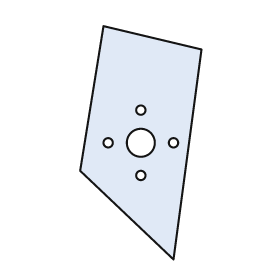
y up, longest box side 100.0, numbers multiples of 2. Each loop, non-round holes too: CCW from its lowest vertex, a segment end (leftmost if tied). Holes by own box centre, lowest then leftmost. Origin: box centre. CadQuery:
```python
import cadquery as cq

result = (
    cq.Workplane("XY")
    .moveTo(14.0, -50.0)
    .lineTo(26.0, 40.0)
    .lineTo(-16.0, 50.0)
    .lineTo(-26.0, -12.0)
    .close()
    .moveTo(0.0, -14.0)
    .circle(2.0)
    .moveTo(-14.0, 0.0)
    .circle(2.0)
    .moveTo(0.0, 0.0)
    .circle(6.0)
    .moveTo(14.0, 0.0)
    .circle(2.0)
    .moveTo(0.0, 14.0)
    .circle(2.0)
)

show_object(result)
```